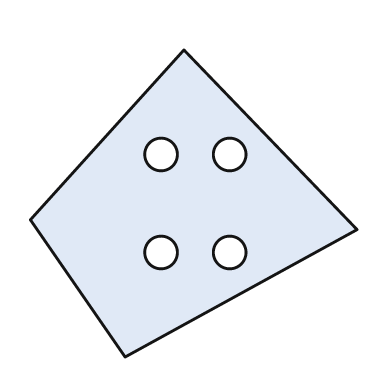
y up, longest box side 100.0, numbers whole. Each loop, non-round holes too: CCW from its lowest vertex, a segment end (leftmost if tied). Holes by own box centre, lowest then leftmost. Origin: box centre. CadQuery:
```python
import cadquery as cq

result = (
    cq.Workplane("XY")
    .moveTo(-21.0, -47.0)
    .lineTo(50.0, -8.0)
    .lineTo(-3.0, 47.0)
    .lineTo(-50.0, -5.0)
    .close()
    .moveTo(-10.0, -15.0)
    .circle(5.0)
    .moveTo(11.0, -15.0)
    .circle(5.0)
    .moveTo(-10.0, 15.0)
    .circle(5.0)
    .moveTo(11.0, 15.0)
    .circle(5.0)
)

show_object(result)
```